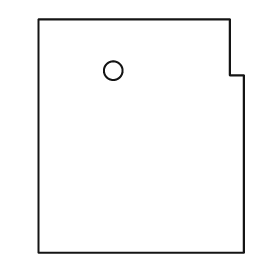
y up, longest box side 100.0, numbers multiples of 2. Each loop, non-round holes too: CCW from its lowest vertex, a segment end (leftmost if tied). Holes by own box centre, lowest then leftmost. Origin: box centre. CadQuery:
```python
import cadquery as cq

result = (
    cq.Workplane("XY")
    .moveTo(-44.0, -50.0)
    .lineTo(44.0, -50.0)
    .lineTo(44.0, 26.0)
    .lineTo(38.0, 26.0)
    .lineTo(38.0, 50.0)
    .lineTo(-44.0, 50.0)
    .close()
    .moveTo(-12.0, 28.0)
    .circle(4.0)
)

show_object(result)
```